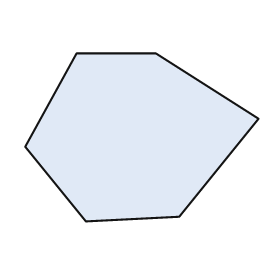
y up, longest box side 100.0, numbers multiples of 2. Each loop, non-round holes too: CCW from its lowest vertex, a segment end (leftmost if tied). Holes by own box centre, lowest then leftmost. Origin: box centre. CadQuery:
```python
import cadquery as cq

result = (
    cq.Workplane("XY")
    .moveTo(-24.0, -36.0)
    .lineTo(16.0, -34.0)
    .lineTo(50.0, 8.0)
    .lineTo(6.0, 36.0)
    .lineTo(-28.0, 36.0)
    .lineTo(-50.0, -4.0)
    .close()
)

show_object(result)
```